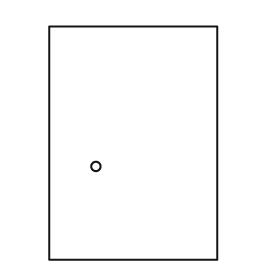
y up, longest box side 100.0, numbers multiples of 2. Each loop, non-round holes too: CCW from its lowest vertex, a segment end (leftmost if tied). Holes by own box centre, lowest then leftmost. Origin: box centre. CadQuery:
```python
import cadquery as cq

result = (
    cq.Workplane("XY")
    .moveTo(-36.0, -50.0)
    .lineTo(36.0, -50.0)
    .lineTo(36.0, 50.0)
    .lineTo(-36.0, 50.0)
    .close()
    .moveTo(-16.0, -10.0)
    .circle(2.0)
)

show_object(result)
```